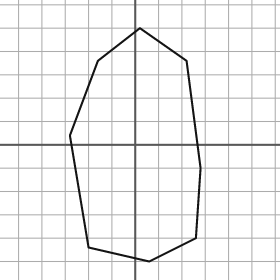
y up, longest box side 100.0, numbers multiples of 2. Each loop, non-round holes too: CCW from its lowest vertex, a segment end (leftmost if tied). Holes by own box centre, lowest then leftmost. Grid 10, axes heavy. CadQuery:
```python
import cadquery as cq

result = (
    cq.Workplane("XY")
    .moveTo(6.0, -50.0)
    .lineTo(26.0, -40.0)
    .lineTo(28.0, -10.0)
    .lineTo(22.0, 36.0)
    .lineTo(2.0, 50.0)
    .lineTo(-16.0, 36.0)
    .lineTo(-28.0, 4.0)
    .lineTo(-20.0, -44.0)
    .close()
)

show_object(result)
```